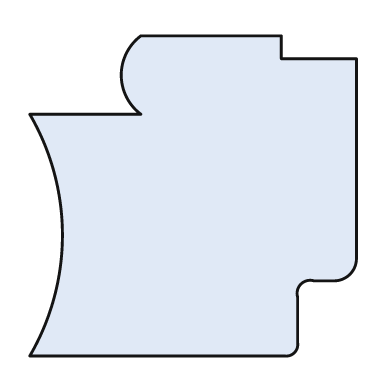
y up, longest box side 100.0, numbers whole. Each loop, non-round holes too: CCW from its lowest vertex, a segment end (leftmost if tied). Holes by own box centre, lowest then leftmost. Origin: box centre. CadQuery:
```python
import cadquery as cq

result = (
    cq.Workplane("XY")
    .moveTo(-50.0, -49.0)
    .lineTo(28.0, -49.0)
    .threePointArc((31.0, -48.0), (32.0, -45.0))
    .lineTo(32.0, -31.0)
    .threePointArc((33.0, -27.0), (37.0, -26.0))
    .lineTo(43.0, -26.0)
    .threePointArc((48.0, -24.0), (50.0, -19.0))
    .lineTo(50.0, 42.0)
    .lineTo(27.0, 42.0)
    .lineTo(27.0, 49.0)
    .lineTo(-16.0, 49.0)
    .threePointArc((-22.0, 37.0), (-16.0, 25.0))
    .lineTo(-50.0, 25.0)
    .threePointArc((-40.0, -12.0), (-50.0, -49.0))
    .close()
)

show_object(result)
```